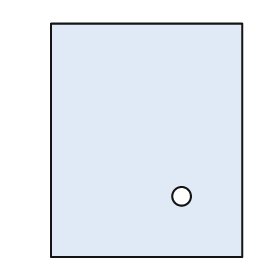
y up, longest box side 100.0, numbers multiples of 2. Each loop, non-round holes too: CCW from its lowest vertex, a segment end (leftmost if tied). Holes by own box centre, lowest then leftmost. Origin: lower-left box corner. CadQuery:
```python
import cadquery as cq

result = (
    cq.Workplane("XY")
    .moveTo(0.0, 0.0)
    .lineTo(82.0, 0.0)
    .lineTo(82.0, 100.0)
    .lineTo(0.0, 100.0)
    .close()
    .moveTo(56.0, 26.0)
    .circle(4.0)
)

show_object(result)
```